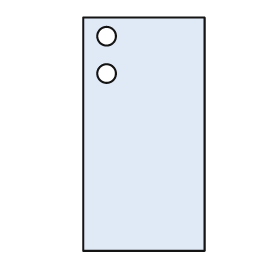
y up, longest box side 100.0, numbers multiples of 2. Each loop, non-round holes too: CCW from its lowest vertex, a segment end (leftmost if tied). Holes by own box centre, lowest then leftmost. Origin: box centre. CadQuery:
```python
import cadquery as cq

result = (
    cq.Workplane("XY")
    .moveTo(-26.0, -50.0)
    .lineTo(26.0, -50.0)
    .lineTo(26.0, 50.0)
    .lineTo(-26.0, 50.0)
    .close()
    .moveTo(-16.0, 26.0)
    .circle(4.0)
    .moveTo(-16.0, 42.0)
    .circle(4.0)
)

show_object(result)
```